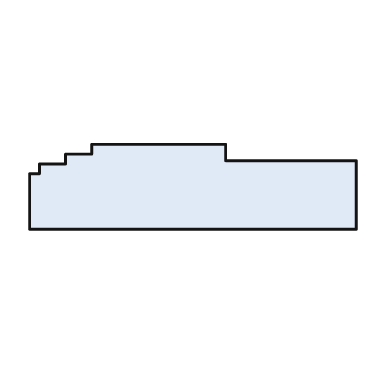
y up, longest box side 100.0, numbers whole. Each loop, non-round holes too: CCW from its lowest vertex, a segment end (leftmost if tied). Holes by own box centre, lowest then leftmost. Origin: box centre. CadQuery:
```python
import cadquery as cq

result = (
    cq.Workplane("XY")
    .moveTo(-50.0, -13.0)
    .lineTo(50.0, -13.0)
    .lineTo(50.0, 8.0)
    .lineTo(10.0, 8.0)
    .lineTo(10.0, 13.0)
    .lineTo(-31.0, 13.0)
    .lineTo(-31.0, 10.0)
    .lineTo(-39.0, 10.0)
    .lineTo(-39.0, 7.0)
    .lineTo(-47.0, 7.0)
    .lineTo(-47.0, 4.0)
    .lineTo(-50.0, 4.0)
    .close()
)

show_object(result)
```